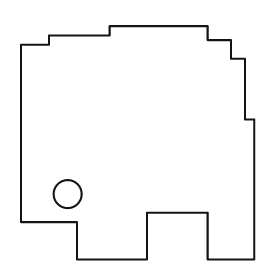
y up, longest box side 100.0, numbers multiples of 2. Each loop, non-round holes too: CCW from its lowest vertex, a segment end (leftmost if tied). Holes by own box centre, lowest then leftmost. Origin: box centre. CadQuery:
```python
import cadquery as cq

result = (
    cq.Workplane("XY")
    .moveTo(-26.0, -50.0)
    .lineTo(4.0, -50.0)
    .lineTo(4.0, -30.0)
    .lineTo(30.0, -30.0)
    .lineTo(30.0, -50.0)
    .lineTo(50.0, -50.0)
    .lineTo(50.0, 10.0)
    .lineTo(46.0, 10.0)
    .lineTo(46.0, 36.0)
    .lineTo(40.0, 36.0)
    .lineTo(40.0, 44.0)
    .lineTo(30.0, 44.0)
    .lineTo(30.0, 50.0)
    .lineTo(-12.0, 50.0)
    .lineTo(-12.0, 46.0)
    .lineTo(-38.0, 46.0)
    .lineTo(-38.0, 42.0)
    .lineTo(-50.0, 42.0)
    .lineTo(-50.0, -34.0)
    .lineTo(-26.0, -34.0)
    .close()
    .moveTo(-30.0, -22.0)
    .circle(6.0)
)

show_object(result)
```